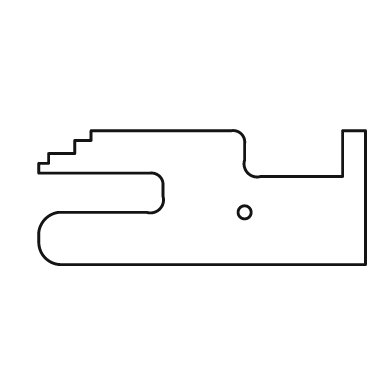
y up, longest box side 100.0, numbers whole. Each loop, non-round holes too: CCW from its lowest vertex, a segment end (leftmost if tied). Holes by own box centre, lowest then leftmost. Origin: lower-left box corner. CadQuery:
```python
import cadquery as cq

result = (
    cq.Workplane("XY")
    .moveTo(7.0, 0.0)
    .lineTo(100.0, 0.0)
    .lineTo(100.0, 41.0)
    .lineTo(93.0, 41.0)
    .lineTo(93.0, 27.0)
    .lineTo(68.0, 27.0)
    .threePointArc((64.0, 28.0), (63.0, 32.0))
    .lineTo(63.0, 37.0)
    .threePointArc((62.0, 40.0), (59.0, 41.0))
    .lineTo(16.0, 41.0)
    .lineTo(16.0, 38.0)
    .lineTo(11.0, 38.0)
    .lineTo(11.0, 34.0)
    .lineTo(3.0, 34.0)
    .lineTo(3.0, 31.0)
    .lineTo(0.0, 31.0)
    .lineTo(0.0, 28.0)
    .lineTo(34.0, 28.0)
    .threePointArc((37.0, 27.0), (38.0, 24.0))
    .lineTo(38.0, 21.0)
    .threePointArc((37.0, 17.0), (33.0, 16.0))
    .lineTo(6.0, 16.0)
    .threePointArc((2.0, 14.0), (0.0, 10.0))
    .lineTo(0.0, 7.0)
    .threePointArc((2.0, 2.0), (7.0, 0.0))
    .close()
    .moveTo(63.0, 16.0)
    .circle(2.0)
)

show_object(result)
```